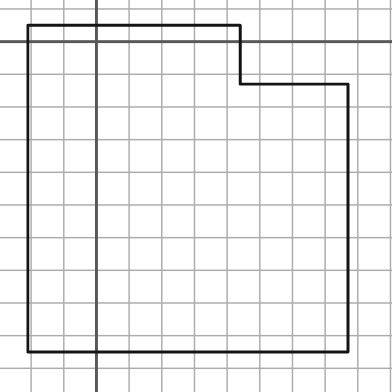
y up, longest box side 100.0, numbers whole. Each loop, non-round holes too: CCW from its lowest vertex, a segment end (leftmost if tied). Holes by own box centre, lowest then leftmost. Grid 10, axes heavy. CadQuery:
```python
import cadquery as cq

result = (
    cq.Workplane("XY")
    .moveTo(-21.0, -95.0)
    .lineTo(77.0, -95.0)
    .lineTo(77.0, -13.0)
    .lineTo(44.0, -13.0)
    .lineTo(44.0, 5.0)
    .lineTo(-21.0, 5.0)
    .close()
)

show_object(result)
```